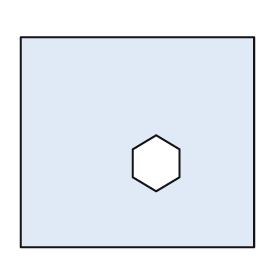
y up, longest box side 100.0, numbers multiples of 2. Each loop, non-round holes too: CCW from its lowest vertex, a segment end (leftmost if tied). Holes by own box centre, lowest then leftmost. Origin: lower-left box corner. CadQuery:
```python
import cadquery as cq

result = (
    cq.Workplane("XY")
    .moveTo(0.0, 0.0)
    .lineTo(100.0, 0.0)
    .lineTo(100.0, 90.0)
    .lineTo(0.0, 90.0)
    .close()
    .moveTo(58.0, 24.0)
    .lineTo(68.0, 30.0)
    .lineTo(68.0, 42.0)
    .lineTo(58.0, 48.0)
    .lineTo(48.0, 42.0)
    .lineTo(48.0, 30.0)
    .close()
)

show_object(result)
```